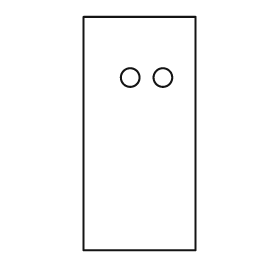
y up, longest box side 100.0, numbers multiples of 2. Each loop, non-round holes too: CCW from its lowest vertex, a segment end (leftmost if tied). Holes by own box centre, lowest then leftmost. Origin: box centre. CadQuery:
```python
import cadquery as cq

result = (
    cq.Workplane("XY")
    .moveTo(-24.0, -50.0)
    .lineTo(24.0, -50.0)
    .lineTo(24.0, 50.0)
    .lineTo(-24.0, 50.0)
    .close()
    .moveTo(-4.0, 24.0)
    .circle(4.0)
    .moveTo(10.0, 24.0)
    .circle(4.0)
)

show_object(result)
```